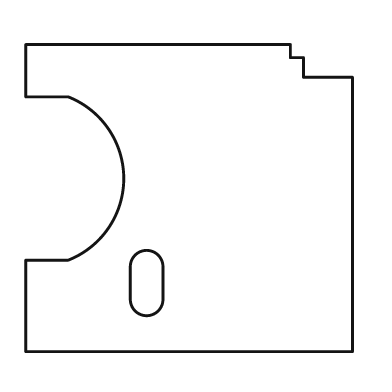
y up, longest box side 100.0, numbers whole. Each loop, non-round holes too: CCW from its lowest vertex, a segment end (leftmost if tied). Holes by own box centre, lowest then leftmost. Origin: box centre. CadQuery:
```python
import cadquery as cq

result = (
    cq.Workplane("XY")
    .moveTo(-50.0, -47.0)
    .lineTo(50.0, -47.0)
    .lineTo(50.0, 37.0)
    .lineTo(35.0, 37.0)
    .lineTo(35.0, 43.0)
    .lineTo(31.0, 43.0)
    .lineTo(31.0, 47.0)
    .lineTo(-50.0, 47.0)
    .lineTo(-50.0, 31.0)
    .lineTo(-37.0, 31.0)
    .threePointArc((-20.0, 6.0), (-37.0, -19.0))
    .lineTo(-50.0, -19.0)
    .close()
    .moveTo(-18.0, -31.0)
    .threePointArc((-13.0, -36.0), (-8.0, -31.0))
    .lineTo(-8.0, -21.0)
    .threePointArc((-13.0, -16.0), (-18.0, -21.0))
    .close()
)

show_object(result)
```